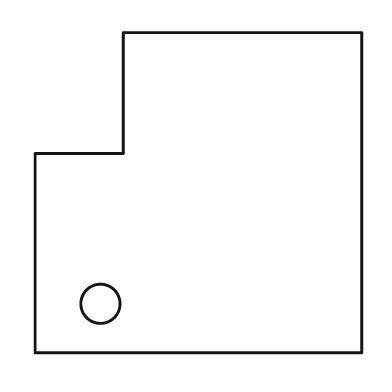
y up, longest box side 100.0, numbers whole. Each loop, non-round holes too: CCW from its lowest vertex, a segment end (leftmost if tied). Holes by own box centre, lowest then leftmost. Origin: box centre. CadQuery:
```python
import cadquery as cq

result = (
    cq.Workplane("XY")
    .moveTo(-50.0, -49.0)
    .lineTo(50.0, -49.0)
    .lineTo(50.0, 49.0)
    .lineTo(-23.0, 49.0)
    .lineTo(-23.0, 12.0)
    .lineTo(-50.0, 12.0)
    .close()
    .moveTo(-30.0, -34.0)
    .circle(6.0)
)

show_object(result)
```